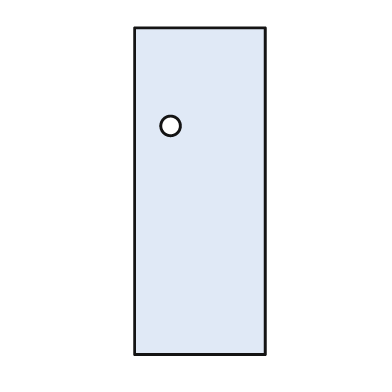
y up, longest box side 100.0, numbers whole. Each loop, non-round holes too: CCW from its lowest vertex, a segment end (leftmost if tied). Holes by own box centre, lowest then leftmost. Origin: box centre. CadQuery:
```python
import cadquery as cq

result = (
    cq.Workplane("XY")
    .moveTo(-20.0, -50.0)
    .lineTo(20.0, -50.0)
    .lineTo(20.0, 50.0)
    .lineTo(-20.0, 50.0)
    .close()
    .moveTo(-9.0, 20.0)
    .circle(3.0)
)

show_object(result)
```